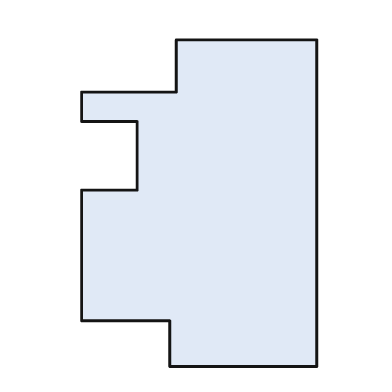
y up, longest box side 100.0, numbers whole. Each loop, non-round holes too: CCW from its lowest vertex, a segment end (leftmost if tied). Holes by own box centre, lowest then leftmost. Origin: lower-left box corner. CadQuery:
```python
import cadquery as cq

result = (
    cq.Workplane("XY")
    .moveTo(27.0, 0.0)
    .lineTo(72.0, 0.0)
    .lineTo(72.0, 100.0)
    .lineTo(29.0, 100.0)
    .lineTo(29.0, 84.0)
    .lineTo(0.0, 84.0)
    .lineTo(0.0, 75.0)
    .lineTo(17.0, 75.0)
    .lineTo(17.0, 54.0)
    .lineTo(0.0, 54.0)
    .lineTo(0.0, 14.0)
    .lineTo(27.0, 14.0)
    .close()
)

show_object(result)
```